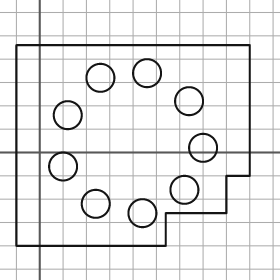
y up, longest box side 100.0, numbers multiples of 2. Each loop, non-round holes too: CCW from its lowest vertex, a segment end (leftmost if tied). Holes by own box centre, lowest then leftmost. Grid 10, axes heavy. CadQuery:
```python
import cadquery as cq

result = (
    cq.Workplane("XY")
    .moveTo(-10.0, -40.0)
    .lineTo(54.0, -40.0)
    .lineTo(54.0, -26.0)
    .lineTo(80.0, -26.0)
    .lineTo(80.0, -10.0)
    .lineTo(90.0, -10.0)
    .lineTo(90.0, 46.0)
    .lineTo(-10.0, 46.0)
    .close()
    .moveTo(44.0, -26.0)
    .circle(6.0)
    .moveTo(24.0, -22.0)
    .circle(6.0)
    .moveTo(62.0, -16.0)
    .circle(6.0)
    .moveTo(10.0, -6.0)
    .circle(6.0)
    .moveTo(70.0, 2.0)
    .circle(6.0)
    .moveTo(12.0, 16.0)
    .circle(6.0)
    .moveTo(64.0, 22.0)
    .circle(6.0)
    .moveTo(26.0, 32.0)
    .circle(6.0)
    .moveTo(46.0, 34.0)
    .circle(6.0)
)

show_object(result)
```